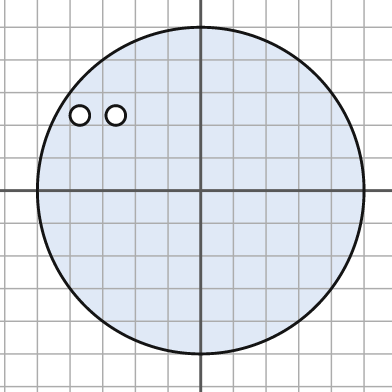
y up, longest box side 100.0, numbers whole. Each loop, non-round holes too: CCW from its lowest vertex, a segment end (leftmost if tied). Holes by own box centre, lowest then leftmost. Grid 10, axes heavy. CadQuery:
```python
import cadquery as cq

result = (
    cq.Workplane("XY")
    .moveTo(0.0, 0.0)
    .circle(50.0)
    .moveTo(-37.0, 23.0)
    .circle(3.0)
    .moveTo(-26.0, 23.0)
    .circle(3.0)
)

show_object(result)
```